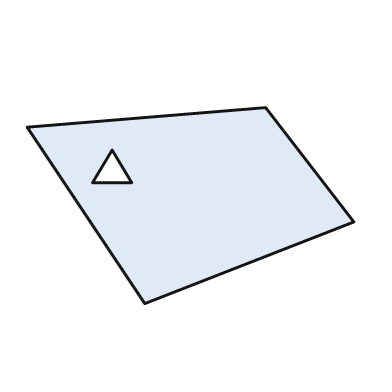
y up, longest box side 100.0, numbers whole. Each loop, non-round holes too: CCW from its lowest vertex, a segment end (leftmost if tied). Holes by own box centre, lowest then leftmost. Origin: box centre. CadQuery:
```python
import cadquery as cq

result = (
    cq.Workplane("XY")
    .moveTo(-14.0, -30.0)
    .lineTo(50.0, -5.0)
    .lineTo(23.0, 30.0)
    .lineTo(-50.0, 24.0)
    .close()
    .moveTo(-30.0, 7.0)
    .lineTo(-18.0, 7.0)
    .lineTo(-24.0, 17.0)
    .close()
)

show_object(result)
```